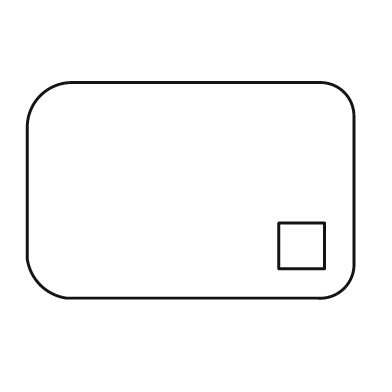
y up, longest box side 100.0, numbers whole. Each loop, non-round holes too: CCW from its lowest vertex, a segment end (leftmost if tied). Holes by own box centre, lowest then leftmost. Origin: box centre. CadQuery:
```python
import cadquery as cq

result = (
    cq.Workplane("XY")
    .moveTo(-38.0, -33.0)
    .lineTo(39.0, -33.0)
    .threePointArc((47.0, -30.0), (50.0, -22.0))
    .lineTo(50.0, 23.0)
    .threePointArc((47.0, 30.0), (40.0, 33.0))
    .lineTo(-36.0, 33.0)
    .threePointArc((-46.0, 29.0), (-50.0, 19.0))
    .lineTo(-50.0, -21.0)
    .threePointArc((-46.0, -29.0), (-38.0, -33.0))
    .close()
    .moveTo(27.0, -24.0)
    .lineTo(41.0, -24.0)
    .lineTo(41.0, -10.0)
    .lineTo(27.0, -10.0)
    .close()
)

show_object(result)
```